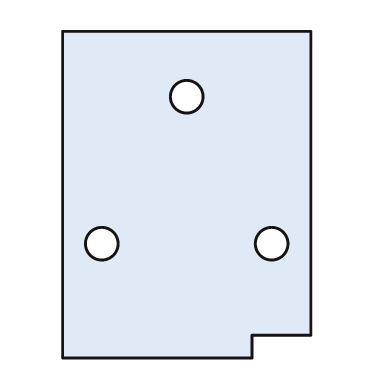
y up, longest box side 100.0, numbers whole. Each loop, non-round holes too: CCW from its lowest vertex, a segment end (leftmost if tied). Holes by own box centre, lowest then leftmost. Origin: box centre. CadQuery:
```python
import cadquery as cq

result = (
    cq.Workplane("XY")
    .moveTo(-38.0, -50.0)
    .lineTo(20.0, -50.0)
    .lineTo(20.0, -43.0)
    .lineTo(38.0, -43.0)
    .lineTo(38.0, 50.0)
    .lineTo(-38.0, 50.0)
    .close()
    .moveTo(-26.0, -15.0)
    .circle(5.0)
    .moveTo(26.0, -15.0)
    .circle(5.0)
    .moveTo(0.0, 30.0)
    .circle(5.0)
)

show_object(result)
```